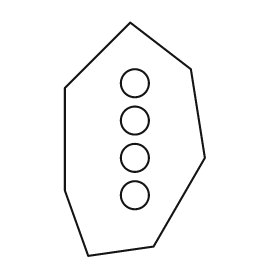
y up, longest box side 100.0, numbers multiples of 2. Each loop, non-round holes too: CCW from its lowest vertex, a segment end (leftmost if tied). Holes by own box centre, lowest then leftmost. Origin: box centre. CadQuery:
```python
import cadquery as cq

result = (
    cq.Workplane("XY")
    .moveTo(-20.0, -50.0)
    .lineTo(8.0, -46.0)
    .lineTo(30.0, -8.0)
    .lineTo(24.0, 30.0)
    .lineTo(-2.0, 50.0)
    .lineTo(-30.0, 22.0)
    .lineTo(-30.0, -22.0)
    .close()
    .moveTo(0.0, -24.0)
    .circle(6.0)
    .moveTo(0.0, -8.0)
    .circle(6.0)
    .moveTo(0.0, 8.0)
    .circle(6.0)
    .moveTo(0.0, 24.0)
    .circle(6.0)
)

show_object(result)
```